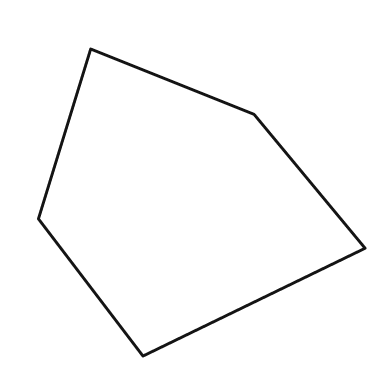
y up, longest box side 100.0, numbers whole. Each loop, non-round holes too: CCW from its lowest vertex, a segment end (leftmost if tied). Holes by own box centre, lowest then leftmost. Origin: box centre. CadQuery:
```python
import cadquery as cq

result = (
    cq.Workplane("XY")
    .moveTo(-18.0, -47.0)
    .lineTo(50.0, -14.0)
    .lineTo(16.0, 27.0)
    .lineTo(-34.0, 47.0)
    .lineTo(-50.0, -5.0)
    .close()
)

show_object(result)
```